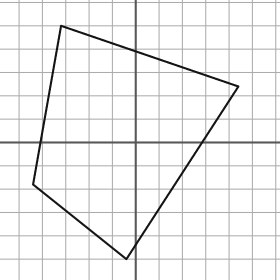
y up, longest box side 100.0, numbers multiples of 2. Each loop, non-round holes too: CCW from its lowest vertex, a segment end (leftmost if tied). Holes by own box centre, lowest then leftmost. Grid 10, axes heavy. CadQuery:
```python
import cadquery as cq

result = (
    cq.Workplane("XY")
    .moveTo(-4.0, -50.0)
    .lineTo(44.0, 24.0)
    .lineTo(-32.0, 50.0)
    .lineTo(-44.0, -18.0)
    .close()
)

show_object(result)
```